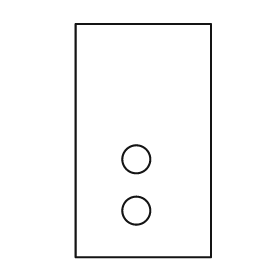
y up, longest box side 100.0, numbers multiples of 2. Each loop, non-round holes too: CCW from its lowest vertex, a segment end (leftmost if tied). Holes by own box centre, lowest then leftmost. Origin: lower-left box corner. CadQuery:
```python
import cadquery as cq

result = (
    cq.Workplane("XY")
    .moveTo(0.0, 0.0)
    .lineTo(58.0, 0.0)
    .lineTo(58.0, 100.0)
    .lineTo(0.0, 100.0)
    .close()
    .moveTo(26.0, 20.0)
    .circle(6.0)
    .moveTo(26.0, 42.0)
    .circle(6.0)
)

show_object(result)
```